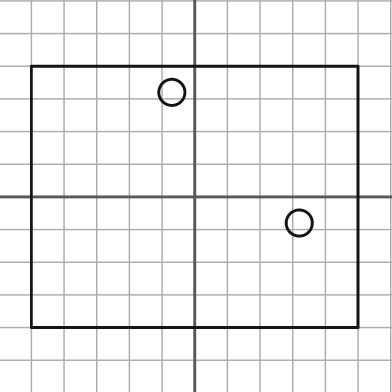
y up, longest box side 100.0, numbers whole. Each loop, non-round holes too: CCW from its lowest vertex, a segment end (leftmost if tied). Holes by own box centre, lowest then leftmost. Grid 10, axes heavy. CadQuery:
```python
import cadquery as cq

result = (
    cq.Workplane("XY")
    .moveTo(-50.0, -40.0)
    .lineTo(50.0, -40.0)
    .lineTo(50.0, 40.0)
    .lineTo(-50.0, 40.0)
    .close()
    .moveTo(32.0, -8.0)
    .circle(4.0)
    .moveTo(-7.0, 32.0)
    .circle(4.0)
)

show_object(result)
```